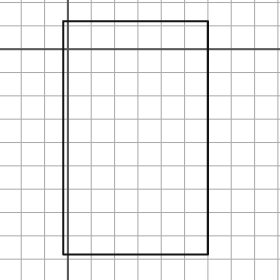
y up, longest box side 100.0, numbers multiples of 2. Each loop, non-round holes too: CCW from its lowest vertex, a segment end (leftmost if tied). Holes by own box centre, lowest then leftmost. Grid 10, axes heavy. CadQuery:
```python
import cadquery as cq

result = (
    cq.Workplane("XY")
    .moveTo(-2.0, -88.0)
    .lineTo(60.0, -88.0)
    .lineTo(60.0, 12.0)
    .lineTo(-2.0, 12.0)
    .close()
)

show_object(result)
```